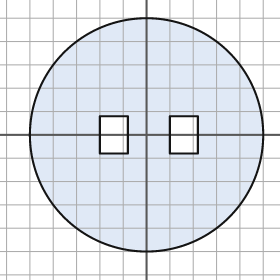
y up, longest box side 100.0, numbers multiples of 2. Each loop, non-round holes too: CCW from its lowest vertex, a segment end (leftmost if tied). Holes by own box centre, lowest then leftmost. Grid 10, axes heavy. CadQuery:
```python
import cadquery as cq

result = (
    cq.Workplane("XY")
    .moveTo(0.0, 0.0)
    .circle(50.0)
    .moveTo(-20.0, -8.0)
    .lineTo(-8.0, -8.0)
    .lineTo(-8.0, 8.0)
    .lineTo(-20.0, 8.0)
    .close()
    .moveTo(10.0, -8.0)
    .lineTo(22.0, -8.0)
    .lineTo(22.0, 8.0)
    .lineTo(10.0, 8.0)
    .close()
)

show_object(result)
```